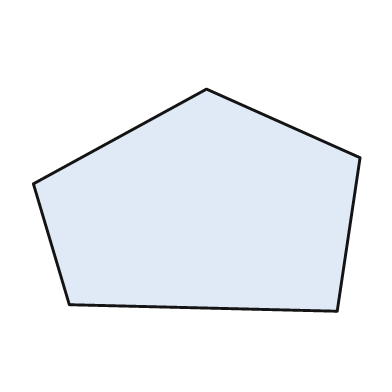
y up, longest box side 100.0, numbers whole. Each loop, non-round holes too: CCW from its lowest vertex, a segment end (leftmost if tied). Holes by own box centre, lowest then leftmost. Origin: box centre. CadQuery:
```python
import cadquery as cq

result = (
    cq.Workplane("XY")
    .moveTo(43.0, -34.0)
    .lineTo(50.0, 13.0)
    .lineTo(3.0, 34.0)
    .lineTo(-50.0, 5.0)
    .lineTo(-39.0, -32.0)
    .close()
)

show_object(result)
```